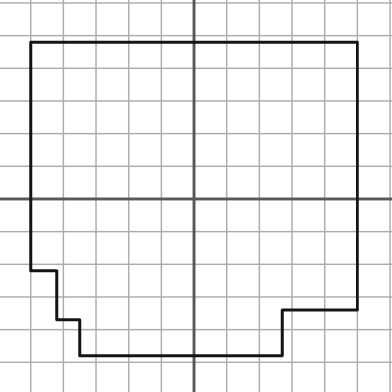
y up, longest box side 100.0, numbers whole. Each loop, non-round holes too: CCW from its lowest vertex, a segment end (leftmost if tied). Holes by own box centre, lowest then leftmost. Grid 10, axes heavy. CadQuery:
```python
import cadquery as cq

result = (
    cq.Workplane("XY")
    .moveTo(-35.0, -48.0)
    .lineTo(27.0, -48.0)
    .lineTo(27.0, -34.0)
    .lineTo(50.0, -34.0)
    .lineTo(50.0, 48.0)
    .lineTo(-50.0, 48.0)
    .lineTo(-50.0, -22.0)
    .lineTo(-42.0, -22.0)
    .lineTo(-42.0, -37.0)
    .lineTo(-35.0, -37.0)
    .close()
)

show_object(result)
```